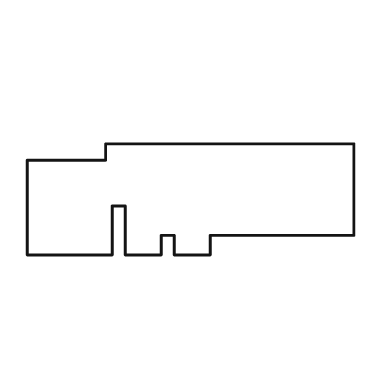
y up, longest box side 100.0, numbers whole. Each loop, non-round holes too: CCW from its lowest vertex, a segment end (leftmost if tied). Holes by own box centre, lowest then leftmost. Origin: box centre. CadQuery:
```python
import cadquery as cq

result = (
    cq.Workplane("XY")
    .moveTo(-50.0, -17.0)
    .lineTo(-24.0, -17.0)
    .lineTo(-24.0, -2.0)
    .lineTo(-20.0, -2.0)
    .lineTo(-20.0, -17.0)
    .lineTo(-9.0, -17.0)
    .lineTo(-9.0, -11.0)
    .lineTo(-5.0, -11.0)
    .lineTo(-5.0, -17.0)
    .lineTo(6.0, -17.0)
    .lineTo(6.0, -11.0)
    .lineTo(50.0, -11.0)
    .lineTo(50.0, 17.0)
    .lineTo(-26.0, 17.0)
    .lineTo(-26.0, 12.0)
    .lineTo(-50.0, 12.0)
    .close()
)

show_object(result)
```